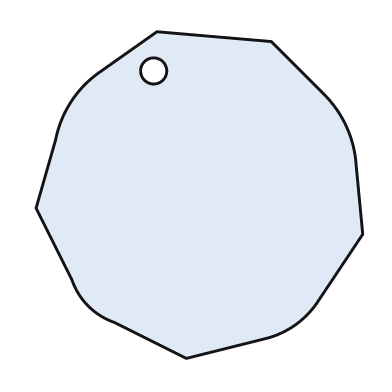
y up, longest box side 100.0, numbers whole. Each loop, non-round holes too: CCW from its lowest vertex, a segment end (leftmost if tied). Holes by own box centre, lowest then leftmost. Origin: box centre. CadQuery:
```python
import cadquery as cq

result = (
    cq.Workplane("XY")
    .moveTo(-4.0, -50.0)
    .lineTo(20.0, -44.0)
    .threePointArc((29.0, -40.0), (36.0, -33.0))
    .lineTo(50.0, -12.0)
    .lineTo(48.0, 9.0)
    .threePointArc((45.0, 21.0), (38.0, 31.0))
    .lineTo(22.0, 47.0)
    .lineTo(-13.0, 50.0)
    .lineTo(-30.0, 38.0)
    .threePointArc((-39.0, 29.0), (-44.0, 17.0))
    .lineTo(-50.0, -4.0)
    .lineTo(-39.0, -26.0)
    .threePointArc((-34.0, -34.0), (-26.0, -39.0))
    .close()
    .moveTo(-14.0, 38.0)
    .circle(4.0)
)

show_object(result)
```